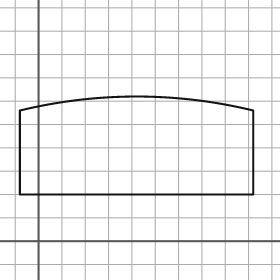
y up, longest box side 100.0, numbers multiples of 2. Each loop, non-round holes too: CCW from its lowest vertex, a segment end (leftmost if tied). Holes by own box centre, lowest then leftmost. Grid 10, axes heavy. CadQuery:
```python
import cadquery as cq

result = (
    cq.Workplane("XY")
    .moveTo(-8.0, 20.0)
    .lineTo(92.0, 20.0)
    .lineTo(92.0, 56.0)
    .threePointArc((42.0, 62.0), (-8.0, 56.0))
    .close()
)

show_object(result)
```